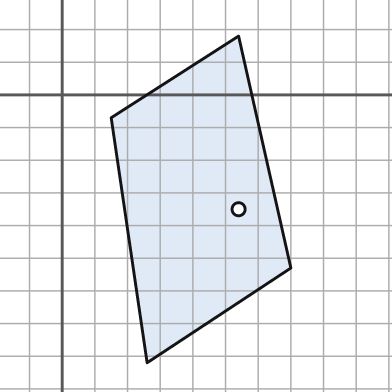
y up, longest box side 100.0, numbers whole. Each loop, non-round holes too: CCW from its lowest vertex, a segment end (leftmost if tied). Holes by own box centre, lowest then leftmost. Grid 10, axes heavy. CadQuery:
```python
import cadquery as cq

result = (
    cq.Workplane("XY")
    .moveTo(26.0, -82.0)
    .lineTo(70.0, -53.0)
    .lineTo(54.0, 18.0)
    .lineTo(15.0, -7.0)
    .close()
    .moveTo(54.0, -35.0)
    .circle(2.0)
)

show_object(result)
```